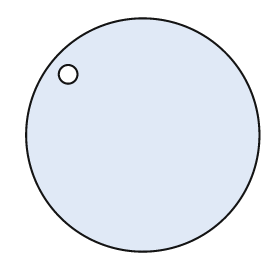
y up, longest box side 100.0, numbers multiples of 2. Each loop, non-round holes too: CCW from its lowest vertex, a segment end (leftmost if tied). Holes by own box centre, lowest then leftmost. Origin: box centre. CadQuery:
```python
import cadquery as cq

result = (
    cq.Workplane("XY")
    .moveTo(0.0, 0.0)
    .circle(50.0)
    .moveTo(-32.0, 26.0)
    .circle(4.0)
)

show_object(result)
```